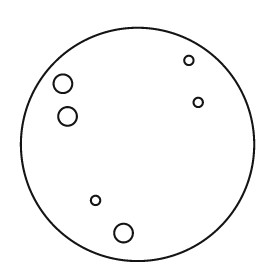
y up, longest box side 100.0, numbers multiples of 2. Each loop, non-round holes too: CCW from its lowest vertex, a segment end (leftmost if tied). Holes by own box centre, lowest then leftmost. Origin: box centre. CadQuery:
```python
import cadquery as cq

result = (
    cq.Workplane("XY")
    .moveTo(0.0, 0.0)
    .circle(50.0)
    .moveTo(-6.0, -38.0)
    .circle(4.0)
    .moveTo(-18.0, -24.0)
    .circle(2.0)
    .moveTo(-30.0, 12.0)
    .circle(4.0)
    .moveTo(26.0, 18.0)
    .circle(2.0)
    .moveTo(-32.0, 26.0)
    .circle(4.0)
    .moveTo(22.0, 36.0)
    .circle(2.0)
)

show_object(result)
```